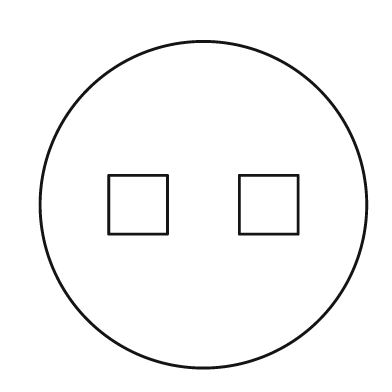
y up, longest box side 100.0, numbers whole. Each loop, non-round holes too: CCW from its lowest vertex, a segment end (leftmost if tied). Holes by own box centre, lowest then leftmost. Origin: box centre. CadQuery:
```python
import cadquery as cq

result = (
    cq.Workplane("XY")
    .moveTo(0.0, 0.0)
    .circle(50.0)
    .moveTo(-29.0, -9.0)
    .lineTo(-11.0, -9.0)
    .lineTo(-11.0, 9.0)
    .lineTo(-29.0, 9.0)
    .close()
    .moveTo(11.0, -9.0)
    .lineTo(29.0, -9.0)
    .lineTo(29.0, 9.0)
    .lineTo(11.0, 9.0)
    .close()
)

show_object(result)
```